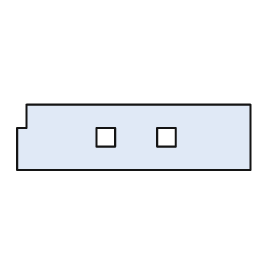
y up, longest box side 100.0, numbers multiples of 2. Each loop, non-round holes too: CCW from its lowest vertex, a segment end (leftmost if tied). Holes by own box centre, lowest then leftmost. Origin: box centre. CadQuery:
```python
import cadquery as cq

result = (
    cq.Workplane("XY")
    .moveTo(-50.0, -14.0)
    .lineTo(50.0, -14.0)
    .lineTo(50.0, 14.0)
    .lineTo(-46.0, 14.0)
    .lineTo(-46.0, 4.0)
    .lineTo(-50.0, 4.0)
    .close()
    .moveTo(-16.0, -4.0)
    .lineTo(-8.0, -4.0)
    .lineTo(-8.0, 4.0)
    .lineTo(-16.0, 4.0)
    .close()
    .moveTo(10.0, -4.0)
    .lineTo(18.0, -4.0)
    .lineTo(18.0, 4.0)
    .lineTo(10.0, 4.0)
    .close()
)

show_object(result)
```